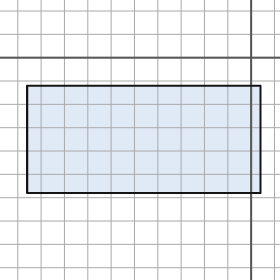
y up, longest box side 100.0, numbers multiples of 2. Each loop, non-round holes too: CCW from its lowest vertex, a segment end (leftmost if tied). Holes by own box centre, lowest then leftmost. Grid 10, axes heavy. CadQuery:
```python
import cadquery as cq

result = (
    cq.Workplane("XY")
    .moveTo(-96.0, -58.0)
    .lineTo(4.0, -58.0)
    .lineTo(4.0, -12.0)
    .lineTo(-96.0, -12.0)
    .close()
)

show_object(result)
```